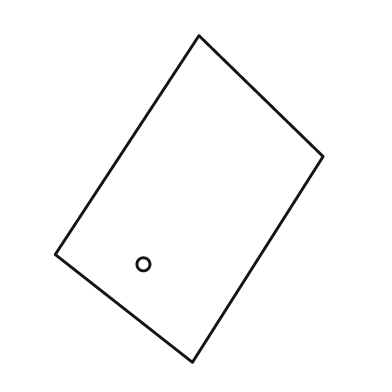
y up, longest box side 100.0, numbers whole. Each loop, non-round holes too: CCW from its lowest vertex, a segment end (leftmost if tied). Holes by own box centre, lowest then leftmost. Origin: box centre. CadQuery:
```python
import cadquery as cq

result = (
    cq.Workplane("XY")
    .moveTo(1.0, -50.0)
    .lineTo(41.0, 13.0)
    .lineTo(3.0, 50.0)
    .lineTo(-41.0, -17.0)
    .close()
    .moveTo(-14.0, -20.0)
    .circle(2.0)
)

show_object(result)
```